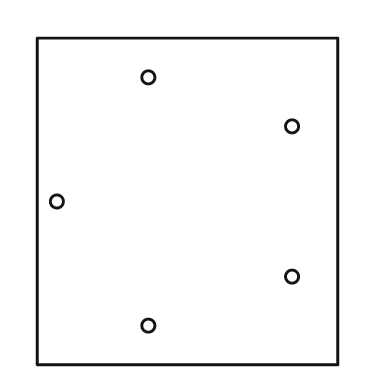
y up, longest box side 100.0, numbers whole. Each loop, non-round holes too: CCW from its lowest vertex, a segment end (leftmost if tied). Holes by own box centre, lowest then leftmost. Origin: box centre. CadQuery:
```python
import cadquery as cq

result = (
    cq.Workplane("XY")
    .moveTo(-46.0, -50.0)
    .lineTo(46.0, -50.0)
    .lineTo(46.0, 50.0)
    .lineTo(-46.0, 50.0)
    .close()
    .moveTo(-12.0, -38.0)
    .circle(2.0)
    .moveTo(32.0, -23.0)
    .circle(2.0)
    .moveTo(-40.0, 0.0)
    .circle(2.0)
    .moveTo(32.0, 23.0)
    .circle(2.0)
    .moveTo(-12.0, 38.0)
    .circle(2.0)
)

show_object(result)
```